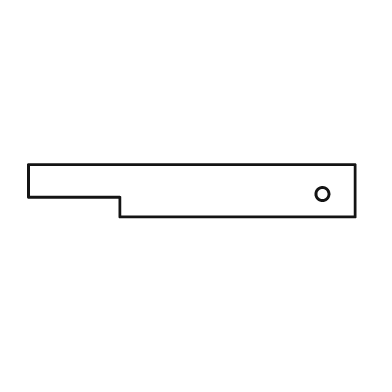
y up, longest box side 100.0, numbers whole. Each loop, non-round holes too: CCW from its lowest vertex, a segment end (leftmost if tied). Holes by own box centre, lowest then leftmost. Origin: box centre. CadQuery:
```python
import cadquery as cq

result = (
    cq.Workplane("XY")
    .moveTo(-22.0, -8.0)
    .lineTo(50.0, -8.0)
    .lineTo(50.0, 8.0)
    .lineTo(-50.0, 8.0)
    .lineTo(-50.0, -2.0)
    .lineTo(-22.0, -2.0)
    .close()
    .moveTo(40.0, -1.0)
    .circle(2.0)
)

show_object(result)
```